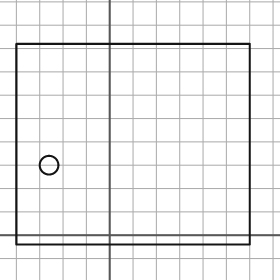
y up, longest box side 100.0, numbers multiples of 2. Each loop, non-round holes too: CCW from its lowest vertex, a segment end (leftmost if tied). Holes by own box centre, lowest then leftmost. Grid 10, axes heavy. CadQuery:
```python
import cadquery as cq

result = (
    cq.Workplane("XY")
    .moveTo(-40.0, -4.0)
    .lineTo(60.0, -4.0)
    .lineTo(60.0, 82.0)
    .lineTo(-40.0, 82.0)
    .close()
    .moveTo(-26.0, 30.0)
    .circle(4.0)
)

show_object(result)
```